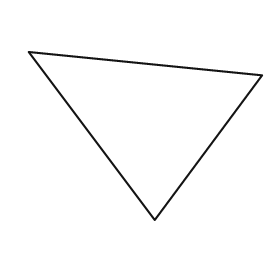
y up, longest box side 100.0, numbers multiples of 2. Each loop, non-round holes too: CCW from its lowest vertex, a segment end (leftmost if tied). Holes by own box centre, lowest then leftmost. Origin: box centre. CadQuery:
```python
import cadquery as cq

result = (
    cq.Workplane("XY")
    .moveTo(4.0, -36.0)
    .lineTo(50.0, 26.0)
    .lineTo(-50.0, 36.0)
    .close()
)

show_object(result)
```